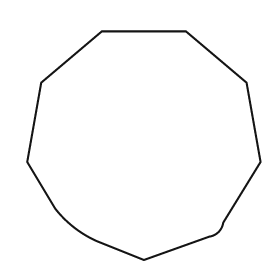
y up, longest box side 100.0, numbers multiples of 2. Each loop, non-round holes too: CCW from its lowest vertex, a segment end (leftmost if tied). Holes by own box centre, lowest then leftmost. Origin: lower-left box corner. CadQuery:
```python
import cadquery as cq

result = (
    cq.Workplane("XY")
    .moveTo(50.0, 0.0)
    .lineTo(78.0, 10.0)
    .threePointArc((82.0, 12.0), (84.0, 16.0))
    .lineTo(100.0, 42.0)
    .lineTo(94.0, 76.0)
    .lineTo(68.0, 98.0)
    .lineTo(32.0, 98.0)
    .lineTo(6.0, 76.0)
    .lineTo(0.0, 42.0)
    .lineTo(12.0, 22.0)
    .threePointArc((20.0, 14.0), (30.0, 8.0))
    .close()
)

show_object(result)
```